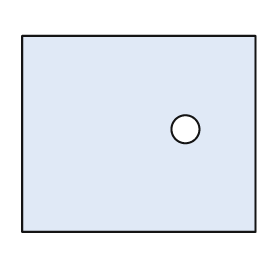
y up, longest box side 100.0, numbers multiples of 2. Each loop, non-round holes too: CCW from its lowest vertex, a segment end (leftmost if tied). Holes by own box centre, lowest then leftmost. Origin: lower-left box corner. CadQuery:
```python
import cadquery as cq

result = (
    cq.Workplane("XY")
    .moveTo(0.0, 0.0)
    .lineTo(100.0, 0.0)
    .lineTo(100.0, 84.0)
    .lineTo(0.0, 84.0)
    .close()
    .moveTo(70.0, 44.0)
    .circle(6.0)
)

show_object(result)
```